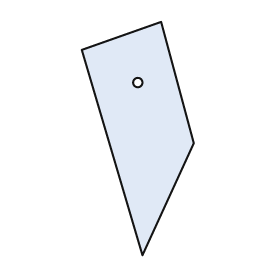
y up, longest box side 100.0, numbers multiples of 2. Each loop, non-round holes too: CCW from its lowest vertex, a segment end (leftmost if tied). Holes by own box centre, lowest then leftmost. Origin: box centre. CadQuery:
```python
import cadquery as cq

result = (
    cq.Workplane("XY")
    .moveTo(2.0, -50.0)
    .lineTo(24.0, -2.0)
    .lineTo(10.0, 50.0)
    .lineTo(-24.0, 38.0)
    .close()
    .moveTo(0.0, 24.0)
    .circle(2.0)
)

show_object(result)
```